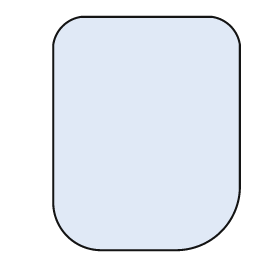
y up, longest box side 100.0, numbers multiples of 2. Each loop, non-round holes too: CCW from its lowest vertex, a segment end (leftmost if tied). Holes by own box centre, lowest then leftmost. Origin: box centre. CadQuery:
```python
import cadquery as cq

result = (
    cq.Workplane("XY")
    .moveTo(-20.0, -50.0)
    .lineTo(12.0, -50.0)
    .threePointArc((32.0, -42.0), (40.0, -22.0))
    .lineTo(40.0, 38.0)
    .threePointArc((36.0, 46.0), (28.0, 50.0))
    .lineTo(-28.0, 50.0)
    .threePointArc((-36.0, 46.0), (-40.0, 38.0))
    .lineTo(-40.0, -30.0)
    .threePointArc((-34.0, -44.0), (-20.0, -50.0))
    .close()
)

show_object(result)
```